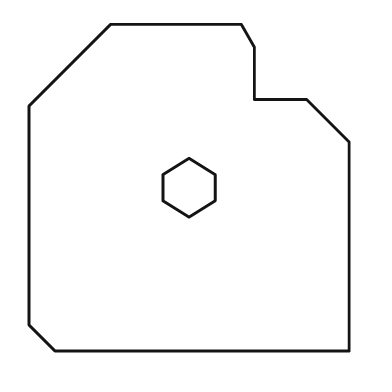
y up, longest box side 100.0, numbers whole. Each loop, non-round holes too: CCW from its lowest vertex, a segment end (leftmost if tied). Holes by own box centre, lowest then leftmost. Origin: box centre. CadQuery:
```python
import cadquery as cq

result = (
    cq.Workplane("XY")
    .moveTo(-41.0, -50.0)
    .lineTo(49.0, -50.0)
    .lineTo(49.0, 14.0)
    .lineTo(36.0, 27.0)
    .lineTo(20.0, 27.0)
    .lineTo(20.0, 43.0)
    .lineTo(16.0, 50.0)
    .lineTo(-24.0, 50.0)
    .lineTo(-49.0, 25.0)
    .lineTo(-49.0, -42.0)
    .close()
    .moveTo(0.0, -9.0)
    .lineTo(8.0, -4.0)
    .lineTo(8.0, 4.0)
    .lineTo(0.0, 9.0)
    .lineTo(-8.0, 4.0)
    .lineTo(-8.0, -4.0)
    .close()
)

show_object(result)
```